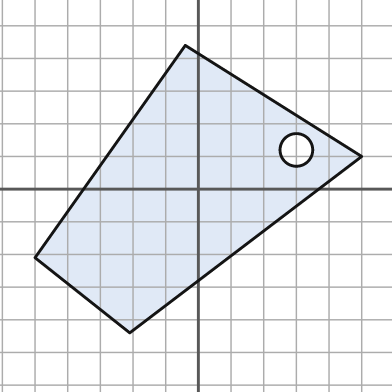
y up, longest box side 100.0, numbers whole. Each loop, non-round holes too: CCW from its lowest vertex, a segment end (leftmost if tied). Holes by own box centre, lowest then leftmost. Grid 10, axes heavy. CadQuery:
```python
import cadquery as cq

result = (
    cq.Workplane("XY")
    .moveTo(-21.0, -44.0)
    .lineTo(50.0, 10.0)
    .lineTo(-4.0, 44.0)
    .lineTo(-50.0, -21.0)
    .close()
    .moveTo(30.0, 12.0)
    .circle(5.0)
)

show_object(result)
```